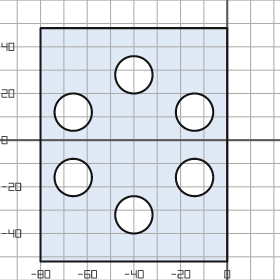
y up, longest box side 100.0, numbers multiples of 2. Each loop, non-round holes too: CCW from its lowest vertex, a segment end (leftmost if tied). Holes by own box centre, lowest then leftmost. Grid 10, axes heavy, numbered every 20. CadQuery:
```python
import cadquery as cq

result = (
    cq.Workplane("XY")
    .moveTo(-80.0, -52.0)
    .lineTo(0.0, -52.0)
    .lineTo(0.0, 48.0)
    .lineTo(-80.0, 48.0)
    .close()
    .moveTo(-40.0, -32.0)
    .circle(8.0)
    .moveTo(-66.0, -16.0)
    .circle(8.0)
    .moveTo(-14.0, -16.0)
    .circle(8.0)
    .moveTo(-66.0, 12.0)
    .circle(8.0)
    .moveTo(-14.0, 12.0)
    .circle(8.0)
    .moveTo(-40.0, 28.0)
    .circle(8.0)
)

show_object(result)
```